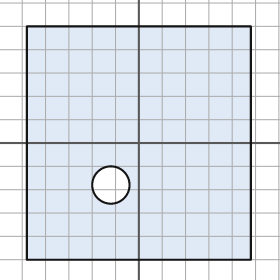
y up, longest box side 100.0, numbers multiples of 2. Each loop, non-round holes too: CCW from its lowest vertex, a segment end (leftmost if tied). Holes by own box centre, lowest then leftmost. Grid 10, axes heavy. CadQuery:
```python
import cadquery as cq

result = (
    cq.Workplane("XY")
    .moveTo(-48.0, -50.0)
    .lineTo(48.0, -50.0)
    .lineTo(48.0, 50.0)
    .lineTo(-48.0, 50.0)
    .close()
    .moveTo(-12.0, -18.0)
    .circle(8.0)
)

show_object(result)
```